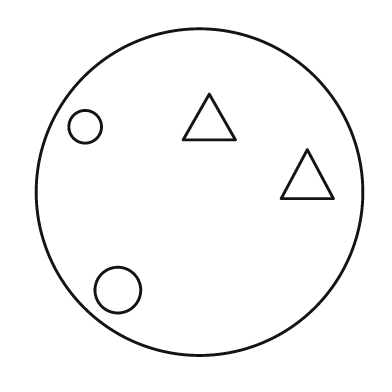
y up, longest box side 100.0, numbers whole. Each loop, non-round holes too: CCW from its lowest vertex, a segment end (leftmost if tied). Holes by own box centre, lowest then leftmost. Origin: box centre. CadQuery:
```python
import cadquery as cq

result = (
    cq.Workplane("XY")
    .moveTo(0.0, 0.0)
    .circle(50.0)
    .moveTo(-25.0, -30.0)
    .circle(7.0)
    .moveTo(25.0, -2.0)
    .lineTo(41.0, -2.0)
    .lineTo(33.0, 13.0)
    .close()
    .moveTo(-35.0, 20.0)
    .circle(5.0)
    .moveTo(-5.0, 16.0)
    .lineTo(11.0, 16.0)
    .lineTo(3.0, 30.0)
    .close()
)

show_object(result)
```